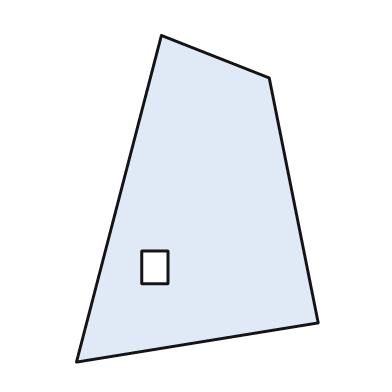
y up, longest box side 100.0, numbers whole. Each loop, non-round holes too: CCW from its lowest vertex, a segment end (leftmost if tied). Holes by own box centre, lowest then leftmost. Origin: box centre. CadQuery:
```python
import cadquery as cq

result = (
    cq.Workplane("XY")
    .moveTo(-37.0, -50.0)
    .lineTo(37.0, -38.0)
    .lineTo(22.0, 37.0)
    .lineTo(-11.0, 50.0)
    .close()
    .moveTo(-17.0, -26.0)
    .lineTo(-9.0, -26.0)
    .lineTo(-9.0, -16.0)
    .lineTo(-17.0, -16.0)
    .close()
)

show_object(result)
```